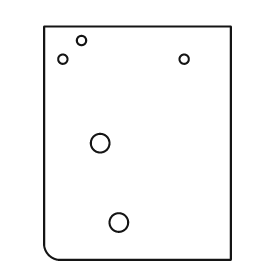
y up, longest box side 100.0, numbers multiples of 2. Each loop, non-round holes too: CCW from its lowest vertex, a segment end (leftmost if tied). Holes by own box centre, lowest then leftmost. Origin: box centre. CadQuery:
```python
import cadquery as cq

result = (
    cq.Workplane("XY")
    .moveTo(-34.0, -50.0)
    .lineTo(40.0, -50.0)
    .lineTo(40.0, 50.0)
    .lineTo(-40.0, 50.0)
    .lineTo(-40.0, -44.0)
    .threePointArc((-38.0, -48.0), (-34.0, -50.0))
    .close()
    .moveTo(-8.0, -34.0)
    .circle(4.0)
    .moveTo(-16.0, 0.0)
    .circle(4.0)
    .moveTo(-32.0, 36.0)
    .circle(2.0)
    .moveTo(20.0, 36.0)
    .circle(2.0)
    .moveTo(-24.0, 44.0)
    .circle(2.0)
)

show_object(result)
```